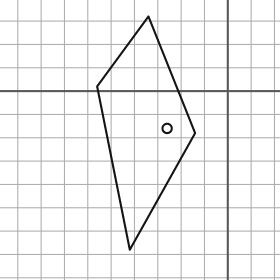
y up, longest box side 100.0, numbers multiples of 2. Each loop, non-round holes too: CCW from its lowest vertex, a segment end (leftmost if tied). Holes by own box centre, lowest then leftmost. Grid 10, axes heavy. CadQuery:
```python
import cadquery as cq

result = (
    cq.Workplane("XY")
    .moveTo(-42.0, -68.0)
    .lineTo(-14.0, -18.0)
    .lineTo(-34.0, 32.0)
    .lineTo(-56.0, 2.0)
    .close()
    .moveTo(-26.0, -16.0)
    .circle(2.0)
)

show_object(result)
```